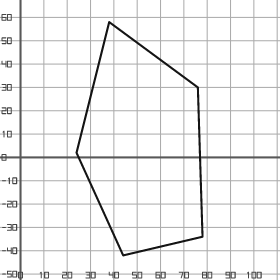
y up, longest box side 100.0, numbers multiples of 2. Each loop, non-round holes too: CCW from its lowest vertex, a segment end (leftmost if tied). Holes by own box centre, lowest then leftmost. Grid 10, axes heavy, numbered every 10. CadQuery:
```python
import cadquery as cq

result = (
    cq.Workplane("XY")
    .moveTo(44.0, -42.0)
    .lineTo(78.0, -34.0)
    .lineTo(76.0, 30.0)
    .lineTo(38.0, 58.0)
    .lineTo(24.0, 2.0)
    .close()
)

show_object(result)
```